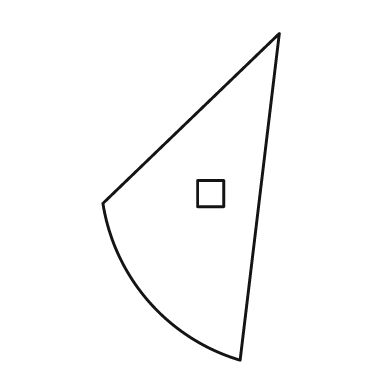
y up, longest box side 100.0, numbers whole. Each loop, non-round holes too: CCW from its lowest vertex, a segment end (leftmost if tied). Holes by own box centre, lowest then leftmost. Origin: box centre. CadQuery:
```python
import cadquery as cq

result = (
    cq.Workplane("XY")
    .moveTo(15.0, -50.0)
    .lineTo(27.0, 50.0)
    .lineTo(-27.0, -2.0)
    .threePointArc((-13.0, -32.0), (15.0, -50.0))
    .close()
    .moveTo(2.0, -3.0)
    .lineTo(10.0, -3.0)
    .lineTo(10.0, 5.0)
    .lineTo(2.0, 5.0)
    .close()
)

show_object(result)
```